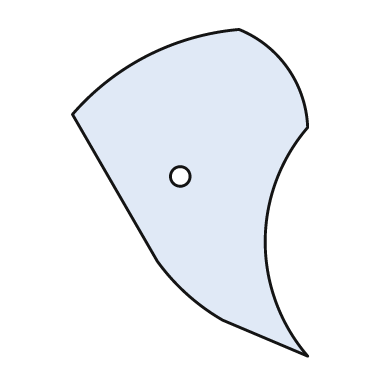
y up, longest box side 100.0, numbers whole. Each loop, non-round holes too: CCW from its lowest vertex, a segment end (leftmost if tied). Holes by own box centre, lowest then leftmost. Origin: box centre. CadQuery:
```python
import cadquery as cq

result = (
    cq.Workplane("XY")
    .moveTo(36.0, -50.0)
    .threePointArc((23.0, -15.0), (36.0, 20.0))
    .threePointArc((30.0, 38.0), (15.0, 50.0))
    .threePointArc((-13.0, 42.0), (-36.0, 24.0))
    .lineTo(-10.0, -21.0)
    .threePointArc((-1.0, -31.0), (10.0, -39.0))
    .close()
    .moveTo(-3.0, 5.0)
    .circle(3.0)
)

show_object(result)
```